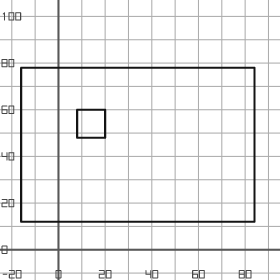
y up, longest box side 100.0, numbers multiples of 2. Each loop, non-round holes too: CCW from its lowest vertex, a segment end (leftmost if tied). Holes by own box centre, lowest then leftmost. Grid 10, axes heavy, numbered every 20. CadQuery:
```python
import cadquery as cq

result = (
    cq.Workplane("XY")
    .moveTo(-16.0, 12.0)
    .lineTo(84.0, 12.0)
    .lineTo(84.0, 78.0)
    .lineTo(-16.0, 78.0)
    .close()
    .moveTo(8.0, 48.0)
    .lineTo(20.0, 48.0)
    .lineTo(20.0, 60.0)
    .lineTo(8.0, 60.0)
    .close()
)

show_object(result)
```